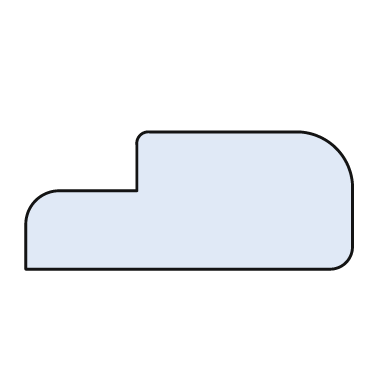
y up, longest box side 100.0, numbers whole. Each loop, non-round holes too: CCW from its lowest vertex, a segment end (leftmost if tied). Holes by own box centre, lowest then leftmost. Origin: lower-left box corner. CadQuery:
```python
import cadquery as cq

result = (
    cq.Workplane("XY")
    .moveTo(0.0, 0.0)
    .lineTo(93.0, 0.0)
    .threePointArc((98.0, 2.0), (100.0, 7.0))
    .lineTo(100.0, 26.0)
    .threePointArc((95.0, 37.0), (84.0, 42.0))
    .lineTo(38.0, 42.0)
    .threePointArc((35.0, 41.0), (34.0, 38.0))
    .lineTo(34.0, 24.0)
    .lineTo(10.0, 24.0)
    .threePointArc((3.0, 21.0), (0.0, 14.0))
    .close()
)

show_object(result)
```